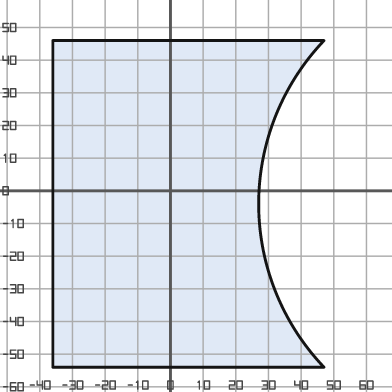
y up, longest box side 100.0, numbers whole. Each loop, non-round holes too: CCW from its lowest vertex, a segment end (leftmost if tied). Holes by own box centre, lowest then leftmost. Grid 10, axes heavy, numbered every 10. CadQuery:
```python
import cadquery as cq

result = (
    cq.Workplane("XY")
    .moveTo(-36.0, -54.0)
    .lineTo(47.0, -54.0)
    .threePointArc((27.0, -4.0), (47.0, 46.0))
    .lineTo(-36.0, 46.0)
    .close()
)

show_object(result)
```